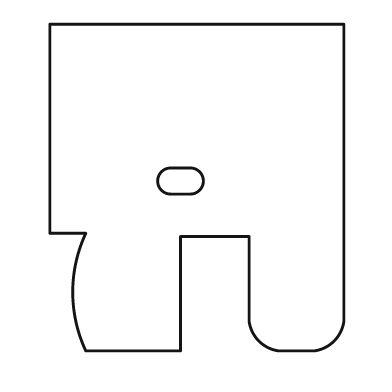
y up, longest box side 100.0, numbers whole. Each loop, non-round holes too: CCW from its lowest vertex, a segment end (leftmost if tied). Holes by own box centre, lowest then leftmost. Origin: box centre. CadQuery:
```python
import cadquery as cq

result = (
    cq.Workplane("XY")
    .moveTo(-34.0, -50.0)
    .lineTo(-5.0, -50.0)
    .lineTo(-5.0, -15.0)
    .lineTo(16.0, -15.0)
    .lineTo(16.0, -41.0)
    .threePointArc((19.0, -47.0), (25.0, -50.0))
    .lineTo(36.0, -50.0)
    .threePointArc((42.0, -47.0), (45.0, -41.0))
    .lineTo(45.0, 50.0)
    .lineTo(-45.0, 50.0)
    .lineTo(-45.0, -14.0)
    .lineTo(-34.0, -14.0)
    .threePointArc((-38.0, -32.0), (-34.0, -50.0))
    .close()
    .moveTo(-8.0, -2.0)
    .lineTo(-2.0, -2.0)
    .threePointArc((2.0, 2.0), (-2.0, 6.0))
    .lineTo(-8.0, 6.0)
    .threePointArc((-12.0, 2.0), (-8.0, -2.0))
    .close()
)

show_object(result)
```